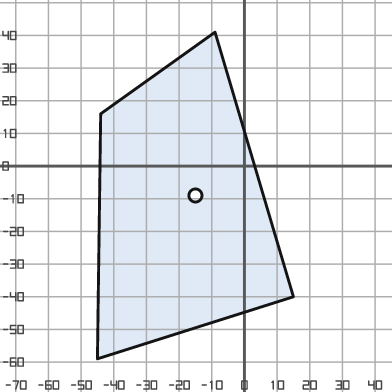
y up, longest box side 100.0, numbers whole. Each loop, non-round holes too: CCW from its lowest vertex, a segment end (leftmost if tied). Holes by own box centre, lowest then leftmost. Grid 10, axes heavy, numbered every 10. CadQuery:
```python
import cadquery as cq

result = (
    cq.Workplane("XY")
    .moveTo(-45.0, -59.0)
    .lineTo(15.0, -40.0)
    .lineTo(-9.0, 41.0)
    .lineTo(-44.0, 16.0)
    .close()
    .moveTo(-15.0, -9.0)
    .circle(2.0)
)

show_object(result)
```